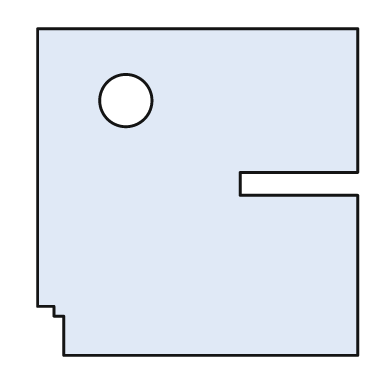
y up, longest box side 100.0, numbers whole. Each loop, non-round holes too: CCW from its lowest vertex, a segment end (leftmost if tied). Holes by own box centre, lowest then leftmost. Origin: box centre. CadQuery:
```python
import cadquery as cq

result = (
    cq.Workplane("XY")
    .moveTo(-41.0, -50.0)
    .lineTo(49.0, -50.0)
    .lineTo(49.0, -1.0)
    .lineTo(13.0, -1.0)
    .lineTo(13.0, 6.0)
    .lineTo(49.0, 6.0)
    .lineTo(49.0, 50.0)
    .lineTo(-49.0, 50.0)
    .lineTo(-49.0, -35.0)
    .lineTo(-44.0, -35.0)
    .lineTo(-44.0, -38.0)
    .lineTo(-41.0, -38.0)
    .close()
    .moveTo(-22.0, 28.0)
    .circle(8.0)
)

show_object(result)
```